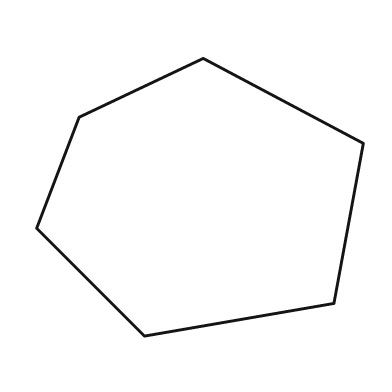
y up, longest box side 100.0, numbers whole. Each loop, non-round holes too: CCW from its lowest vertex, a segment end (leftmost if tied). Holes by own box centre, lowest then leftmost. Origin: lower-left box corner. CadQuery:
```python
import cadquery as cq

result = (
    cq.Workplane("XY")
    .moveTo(33.0, 0.0)
    .lineTo(91.0, 10.0)
    .lineTo(100.0, 59.0)
    .lineTo(51.0, 85.0)
    .lineTo(13.0, 67.0)
    .lineTo(0.0, 33.0)
    .close()
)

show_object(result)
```